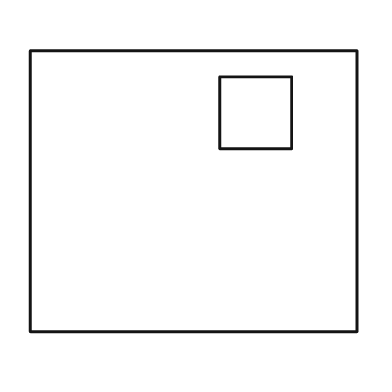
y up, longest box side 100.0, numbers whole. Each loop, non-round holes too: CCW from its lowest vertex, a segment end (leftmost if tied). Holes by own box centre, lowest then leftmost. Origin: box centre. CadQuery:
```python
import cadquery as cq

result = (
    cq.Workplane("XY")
    .moveTo(-50.0, -43.0)
    .lineTo(50.0, -43.0)
    .lineTo(50.0, 43.0)
    .lineTo(-50.0, 43.0)
    .close()
    .moveTo(8.0, 13.0)
    .lineTo(30.0, 13.0)
    .lineTo(30.0, 35.0)
    .lineTo(8.0, 35.0)
    .close()
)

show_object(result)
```